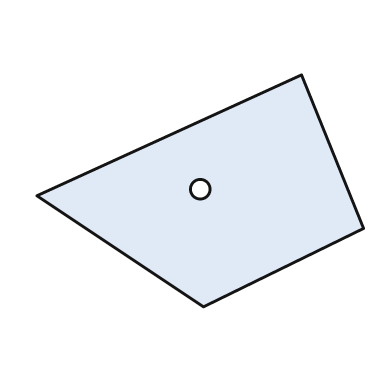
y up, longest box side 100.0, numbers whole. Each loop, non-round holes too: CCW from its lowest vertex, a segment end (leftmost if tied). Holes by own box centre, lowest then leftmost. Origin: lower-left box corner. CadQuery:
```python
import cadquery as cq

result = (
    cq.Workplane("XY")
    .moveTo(51.0, 0.0)
    .lineTo(100.0, 24.0)
    .lineTo(81.0, 71.0)
    .lineTo(0.0, 34.0)
    .close()
    .moveTo(50.0, 36.0)
    .circle(3.0)
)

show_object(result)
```